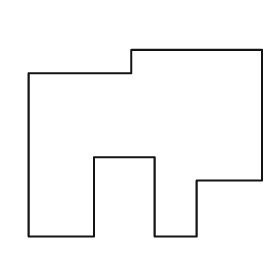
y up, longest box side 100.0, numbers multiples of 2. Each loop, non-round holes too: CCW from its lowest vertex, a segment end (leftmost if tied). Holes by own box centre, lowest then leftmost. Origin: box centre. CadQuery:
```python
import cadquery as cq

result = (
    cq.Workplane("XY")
    .moveTo(-50.0, -40.0)
    .lineTo(-22.0, -40.0)
    .lineTo(-22.0, -6.0)
    .lineTo(4.0, -6.0)
    .lineTo(4.0, -40.0)
    .lineTo(22.0, -40.0)
    .lineTo(22.0, -16.0)
    .lineTo(50.0, -16.0)
    .lineTo(50.0, 40.0)
    .lineTo(-6.0, 40.0)
    .lineTo(-6.0, 30.0)
    .lineTo(-50.0, 30.0)
    .close()
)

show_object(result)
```